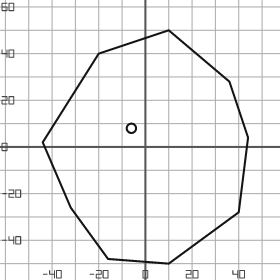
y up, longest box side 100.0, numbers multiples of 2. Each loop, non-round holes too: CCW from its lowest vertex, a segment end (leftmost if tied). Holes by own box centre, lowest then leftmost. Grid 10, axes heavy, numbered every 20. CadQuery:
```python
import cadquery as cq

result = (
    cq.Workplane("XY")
    .moveTo(10.0, -50.0)
    .lineTo(40.0, -28.0)
    .lineTo(44.0, 4.0)
    .lineTo(36.0, 28.0)
    .lineTo(10.0, 50.0)
    .lineTo(-20.0, 40.0)
    .lineTo(-44.0, 2.0)
    .lineTo(-32.0, -26.0)
    .lineTo(-16.0, -48.0)
    .close()
    .moveTo(-6.0, 8.0)
    .circle(2.0)
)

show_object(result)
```